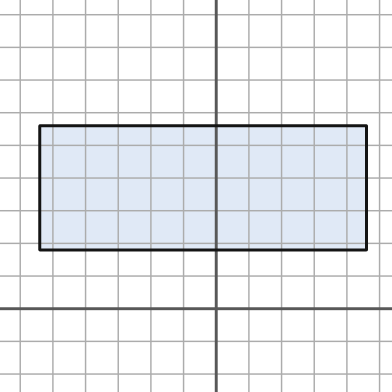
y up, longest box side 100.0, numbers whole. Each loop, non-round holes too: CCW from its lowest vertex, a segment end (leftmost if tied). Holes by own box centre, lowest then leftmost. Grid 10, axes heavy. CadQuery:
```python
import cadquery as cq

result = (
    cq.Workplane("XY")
    .moveTo(-54.0, 18.0)
    .lineTo(46.0, 18.0)
    .lineTo(46.0, 56.0)
    .lineTo(-54.0, 56.0)
    .close()
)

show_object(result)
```